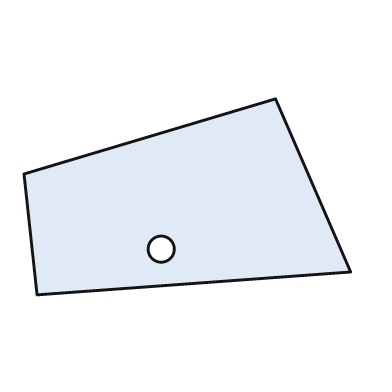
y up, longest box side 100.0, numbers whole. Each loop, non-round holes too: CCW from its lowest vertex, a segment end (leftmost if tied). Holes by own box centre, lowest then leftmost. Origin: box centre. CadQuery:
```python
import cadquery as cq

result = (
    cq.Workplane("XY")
    .moveTo(-46.0, -30.0)
    .lineTo(50.0, -23.0)
    .lineTo(27.0, 30.0)
    .lineTo(-50.0, 7.0)
    .close()
    .moveTo(-8.0, -16.0)
    .circle(4.0)
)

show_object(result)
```